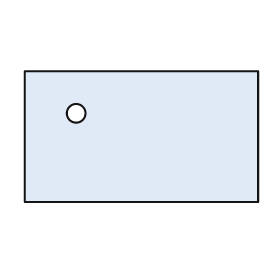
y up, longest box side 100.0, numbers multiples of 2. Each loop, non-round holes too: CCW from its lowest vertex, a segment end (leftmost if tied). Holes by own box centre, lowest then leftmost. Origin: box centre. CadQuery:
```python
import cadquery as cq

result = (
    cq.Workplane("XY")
    .moveTo(-50.0, -28.0)
    .lineTo(50.0, -28.0)
    .lineTo(50.0, 28.0)
    .lineTo(-50.0, 28.0)
    .close()
    .moveTo(-28.0, 10.0)
    .circle(4.0)
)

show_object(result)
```